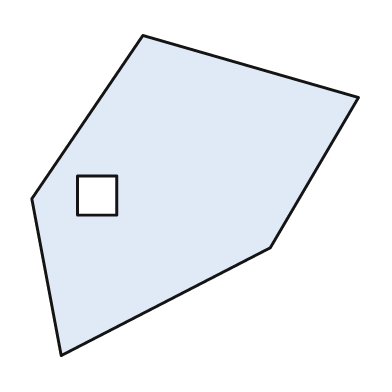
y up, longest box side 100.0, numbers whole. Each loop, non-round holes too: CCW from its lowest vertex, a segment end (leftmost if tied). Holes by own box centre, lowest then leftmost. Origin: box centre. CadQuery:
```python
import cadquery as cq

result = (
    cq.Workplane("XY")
    .moveTo(-41.0, -49.0)
    .lineTo(23.0, -16.0)
    .lineTo(50.0, 30.0)
    .lineTo(-16.0, 49.0)
    .lineTo(-50.0, -1.0)
    .close()
    .moveTo(-36.0, -6.0)
    .lineTo(-24.0, -6.0)
    .lineTo(-24.0, 6.0)
    .lineTo(-36.0, 6.0)
    .close()
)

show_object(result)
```